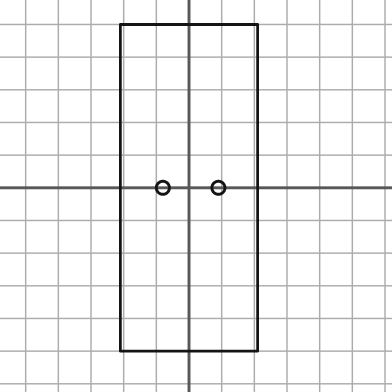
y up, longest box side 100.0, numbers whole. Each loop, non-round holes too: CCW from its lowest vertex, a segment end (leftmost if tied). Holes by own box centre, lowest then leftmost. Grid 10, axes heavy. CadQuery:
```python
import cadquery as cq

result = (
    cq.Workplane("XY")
    .moveTo(-21.0, -50.0)
    .lineTo(21.0, -50.0)
    .lineTo(21.0, 50.0)
    .lineTo(-21.0, 50.0)
    .close()
    .moveTo(-8.0, 0.0)
    .circle(2.0)
    .moveTo(9.0, 0.0)
    .circle(2.0)
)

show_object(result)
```